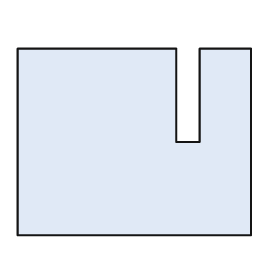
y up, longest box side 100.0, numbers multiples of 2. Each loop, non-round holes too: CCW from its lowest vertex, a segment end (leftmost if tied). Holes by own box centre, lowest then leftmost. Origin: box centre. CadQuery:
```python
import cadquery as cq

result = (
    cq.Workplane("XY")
    .moveTo(-50.0, -40.0)
    .lineTo(50.0, -40.0)
    .lineTo(50.0, 40.0)
    .lineTo(28.0, 40.0)
    .lineTo(28.0, 0.0)
    .lineTo(18.0, 0.0)
    .lineTo(18.0, 40.0)
    .lineTo(-50.0, 40.0)
    .close()
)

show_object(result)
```